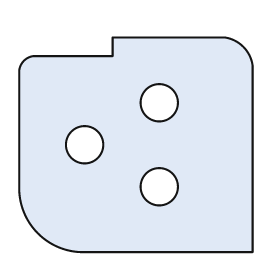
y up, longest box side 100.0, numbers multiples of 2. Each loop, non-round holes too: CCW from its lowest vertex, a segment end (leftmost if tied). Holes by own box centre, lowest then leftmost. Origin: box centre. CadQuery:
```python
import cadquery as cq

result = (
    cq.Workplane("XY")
    .moveTo(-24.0, -46.0)
    .lineTo(50.0, -46.0)
    .lineTo(50.0, 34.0)
    .threePointArc((46.0, 42.0), (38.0, 46.0))
    .lineTo(-10.0, 46.0)
    .lineTo(-10.0, 38.0)
    .lineTo(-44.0, 38.0)
    .threePointArc((-48.0, 36.0), (-50.0, 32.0))
    .lineTo(-50.0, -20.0)
    .threePointArc((-42.0, -38.0), (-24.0, -46.0))
    .close()
    .moveTo(10.0, -18.0)
    .circle(8.0)
    .moveTo(-22.0, 0.0)
    .circle(8.0)
    .moveTo(10.0, 18.0)
    .circle(8.0)
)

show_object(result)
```